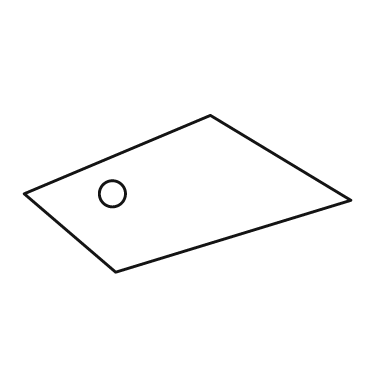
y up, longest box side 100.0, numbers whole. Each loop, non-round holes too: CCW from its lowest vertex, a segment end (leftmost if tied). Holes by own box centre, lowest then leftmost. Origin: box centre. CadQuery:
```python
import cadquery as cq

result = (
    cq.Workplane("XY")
    .moveTo(-22.0, -24.0)
    .lineTo(50.0, -2.0)
    .lineTo(7.0, 24.0)
    .lineTo(-50.0, 0.0)
    .close()
    .moveTo(-23.0, 0.0)
    .circle(4.0)
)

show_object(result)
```